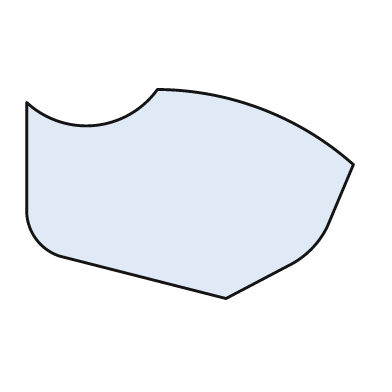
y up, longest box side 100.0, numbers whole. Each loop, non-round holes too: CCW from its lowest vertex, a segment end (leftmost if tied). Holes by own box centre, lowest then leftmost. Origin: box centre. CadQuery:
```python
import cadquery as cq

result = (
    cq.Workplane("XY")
    .moveTo(11.0, -32.0)
    .lineTo(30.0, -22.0)
    .threePointArc((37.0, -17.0), (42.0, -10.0))
    .lineTo(50.0, 9.0)
    .threePointArc((22.0, 26.0), (-10.0, 32.0))
    .threePointArc((-29.0, 21.0), (-50.0, 28.0))
    .lineTo(-50.0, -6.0)
    .threePointArc((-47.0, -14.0), (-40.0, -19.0))
    .close()
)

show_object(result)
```